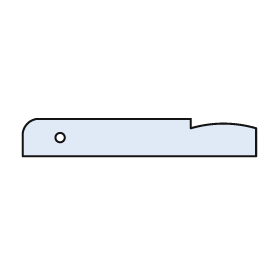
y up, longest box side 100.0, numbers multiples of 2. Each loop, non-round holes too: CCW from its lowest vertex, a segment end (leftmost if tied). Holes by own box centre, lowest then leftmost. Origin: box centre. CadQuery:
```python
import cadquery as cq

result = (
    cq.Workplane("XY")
    .moveTo(-50.0, -8.0)
    .lineTo(50.0, -8.0)
    .lineTo(50.0, 4.0)
    .threePointArc((36.0, 6.0), (22.0, 4.0))
    .lineTo(22.0, 8.0)
    .lineTo(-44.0, 8.0)
    .threePointArc((-48.0, 6.0), (-50.0, 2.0))
    .close()
    .moveTo(-34.0, 0.0)
    .circle(2.0)
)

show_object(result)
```